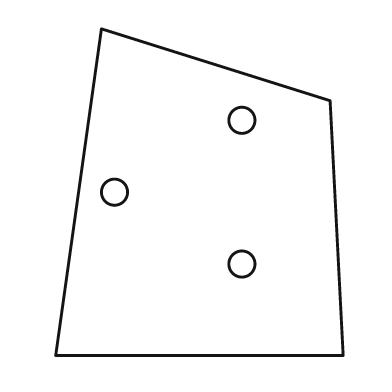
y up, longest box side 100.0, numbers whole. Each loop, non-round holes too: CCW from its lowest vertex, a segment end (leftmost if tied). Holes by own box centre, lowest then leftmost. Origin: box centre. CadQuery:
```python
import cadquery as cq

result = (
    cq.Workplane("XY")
    .moveTo(-44.0, -50.0)
    .lineTo(44.0, -50.0)
    .lineTo(40.0, 28.0)
    .lineTo(-30.0, 50.0)
    .close()
    .moveTo(13.0, -22.0)
    .circle(4.0)
    .moveTo(-26.0, 0.0)
    .circle(4.0)
    .moveTo(13.0, 22.0)
    .circle(4.0)
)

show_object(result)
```